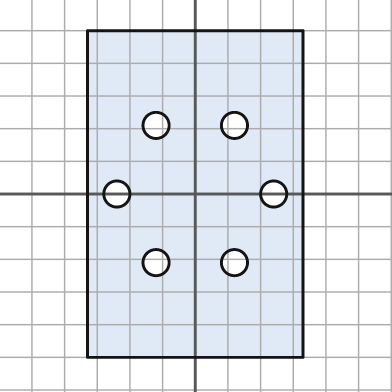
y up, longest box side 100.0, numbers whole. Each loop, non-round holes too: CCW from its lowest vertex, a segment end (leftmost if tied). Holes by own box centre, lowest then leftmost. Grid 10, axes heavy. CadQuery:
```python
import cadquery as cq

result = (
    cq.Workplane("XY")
    .moveTo(-33.0, -50.0)
    .lineTo(33.0, -50.0)
    .lineTo(33.0, 50.0)
    .lineTo(-33.0, 50.0)
    .close()
    .moveTo(-12.0, -21.0)
    .circle(4.0)
    .moveTo(12.0, -21.0)
    .circle(4.0)
    .moveTo(-24.0, 0.0)
    .circle(4.0)
    .moveTo(24.0, 0.0)
    .circle(4.0)
    .moveTo(-12.0, 21.0)
    .circle(4.0)
    .moveTo(12.0, 21.0)
    .circle(4.0)
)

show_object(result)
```